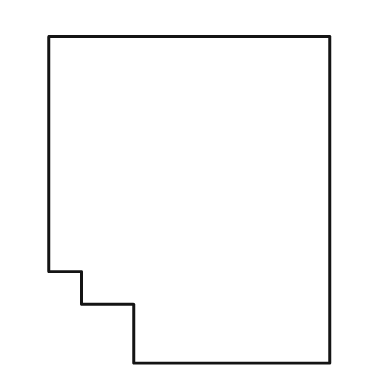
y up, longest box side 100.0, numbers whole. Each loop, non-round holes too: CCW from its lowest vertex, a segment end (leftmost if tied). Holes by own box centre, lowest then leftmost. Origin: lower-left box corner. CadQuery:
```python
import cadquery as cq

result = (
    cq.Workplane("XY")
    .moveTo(26.0, 0.0)
    .lineTo(86.0, 0.0)
    .lineTo(86.0, 100.0)
    .lineTo(0.0, 100.0)
    .lineTo(0.0, 28.0)
    .lineTo(10.0, 28.0)
    .lineTo(10.0, 18.0)
    .lineTo(26.0, 18.0)
    .close()
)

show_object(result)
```